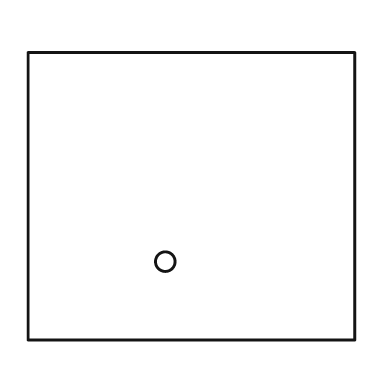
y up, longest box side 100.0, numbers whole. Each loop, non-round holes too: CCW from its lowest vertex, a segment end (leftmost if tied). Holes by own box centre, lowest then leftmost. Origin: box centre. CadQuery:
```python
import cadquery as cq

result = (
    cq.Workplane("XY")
    .moveTo(-50.0, -44.0)
    .lineTo(50.0, -44.0)
    .lineTo(50.0, 44.0)
    .lineTo(-50.0, 44.0)
    .close()
    .moveTo(-8.0, -20.0)
    .circle(3.0)
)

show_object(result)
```